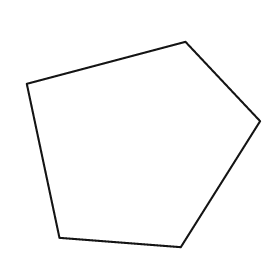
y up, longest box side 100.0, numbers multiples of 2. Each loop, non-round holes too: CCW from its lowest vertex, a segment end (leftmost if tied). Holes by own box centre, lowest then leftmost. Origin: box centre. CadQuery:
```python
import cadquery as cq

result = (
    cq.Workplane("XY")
    .moveTo(16.0, -44.0)
    .lineTo(50.0, 10.0)
    .lineTo(18.0, 44.0)
    .lineTo(-50.0, 26.0)
    .lineTo(-36.0, -40.0)
    .close()
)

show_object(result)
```